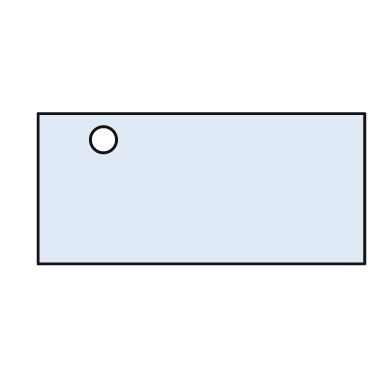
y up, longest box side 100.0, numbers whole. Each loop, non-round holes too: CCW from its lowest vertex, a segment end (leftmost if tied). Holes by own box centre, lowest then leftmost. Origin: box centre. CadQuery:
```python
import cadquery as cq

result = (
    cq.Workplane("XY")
    .moveTo(-50.0, -23.0)
    .lineTo(50.0, -23.0)
    .lineTo(50.0, 23.0)
    .lineTo(-50.0, 23.0)
    .close()
    .moveTo(-30.0, 15.0)
    .circle(4.0)
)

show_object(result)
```